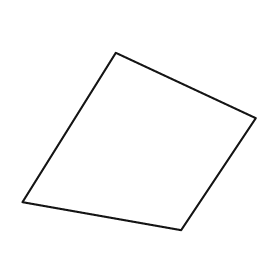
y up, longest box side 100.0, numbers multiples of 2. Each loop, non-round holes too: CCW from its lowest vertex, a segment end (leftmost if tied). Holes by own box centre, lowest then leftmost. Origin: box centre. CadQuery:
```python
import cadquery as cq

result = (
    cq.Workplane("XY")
    .moveTo(18.0, -38.0)
    .lineTo(50.0, 10.0)
    .lineTo(-10.0, 38.0)
    .lineTo(-50.0, -26.0)
    .close()
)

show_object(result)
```